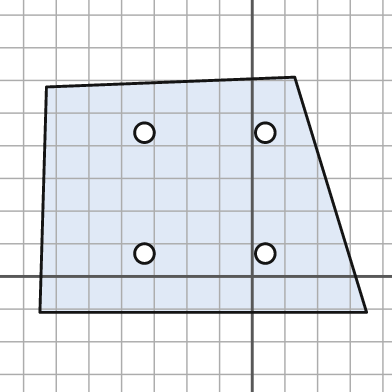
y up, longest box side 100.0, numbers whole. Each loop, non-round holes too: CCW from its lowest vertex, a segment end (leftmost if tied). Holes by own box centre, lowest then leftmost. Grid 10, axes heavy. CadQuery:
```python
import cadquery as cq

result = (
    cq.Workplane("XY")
    .moveTo(-65.0, -11.0)
    .lineTo(35.0, -11.0)
    .lineTo(13.0, 61.0)
    .lineTo(-63.0, 58.0)
    .close()
    .moveTo(-33.0, 7.0)
    .circle(3.0)
    .moveTo(4.0, 7.0)
    .circle(3.0)
    .moveTo(-33.0, 44.0)
    .circle(3.0)
    .moveTo(4.0, 44.0)
    .circle(3.0)
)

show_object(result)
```